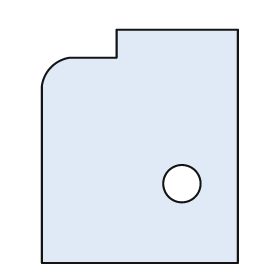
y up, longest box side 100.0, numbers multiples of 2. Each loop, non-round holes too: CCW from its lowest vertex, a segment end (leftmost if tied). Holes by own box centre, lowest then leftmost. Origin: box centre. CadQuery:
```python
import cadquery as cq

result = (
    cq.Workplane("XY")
    .moveTo(-42.0, -50.0)
    .lineTo(42.0, -50.0)
    .lineTo(42.0, 50.0)
    .lineTo(-10.0, 50.0)
    .lineTo(-10.0, 38.0)
    .lineTo(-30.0, 38.0)
    .threePointArc((-38.0, 34.0), (-42.0, 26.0))
    .close()
    .moveTo(18.0, -16.0)
    .circle(8.0)
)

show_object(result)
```